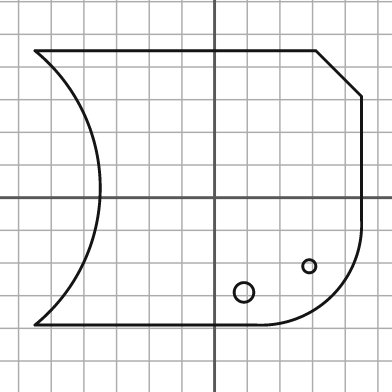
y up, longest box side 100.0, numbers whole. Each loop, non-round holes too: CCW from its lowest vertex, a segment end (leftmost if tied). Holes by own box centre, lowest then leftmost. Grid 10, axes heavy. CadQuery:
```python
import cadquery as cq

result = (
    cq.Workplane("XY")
    .moveTo(-55.0, -39.0)
    .lineTo(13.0, -39.0)
    .threePointArc((36.0, -30.0), (45.0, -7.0))
    .lineTo(45.0, 31.0)
    .lineTo(31.0, 45.0)
    .lineTo(-55.0, 45.0)
    .threePointArc((-35.0, 3.0), (-55.0, -39.0))
    .close()
    .moveTo(9.0, -29.0)
    .circle(3.0)
    .moveTo(29.0, -21.0)
    .circle(2.0)
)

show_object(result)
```